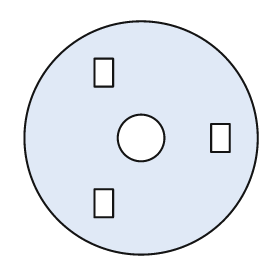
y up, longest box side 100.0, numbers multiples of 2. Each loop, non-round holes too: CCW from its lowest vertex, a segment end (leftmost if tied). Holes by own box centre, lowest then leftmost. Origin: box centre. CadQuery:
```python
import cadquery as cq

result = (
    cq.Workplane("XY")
    .moveTo(0.0, 0.0)
    .circle(50.0)
    .moveTo(-20.0, -34.0)
    .lineTo(-12.0, -34.0)
    .lineTo(-12.0, -22.0)
    .lineTo(-20.0, -22.0)
    .close()
    .moveTo(0.0, 0.0)
    .circle(10.0)
    .moveTo(30.0, -6.0)
    .lineTo(38.0, -6.0)
    .lineTo(38.0, 6.0)
    .lineTo(30.0, 6.0)
    .close()
    .moveTo(-20.0, 22.0)
    .lineTo(-12.0, 22.0)
    .lineTo(-12.0, 34.0)
    .lineTo(-20.0, 34.0)
    .close()
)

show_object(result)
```